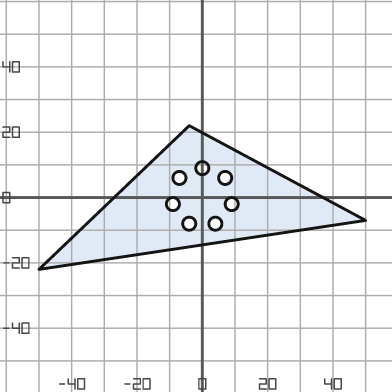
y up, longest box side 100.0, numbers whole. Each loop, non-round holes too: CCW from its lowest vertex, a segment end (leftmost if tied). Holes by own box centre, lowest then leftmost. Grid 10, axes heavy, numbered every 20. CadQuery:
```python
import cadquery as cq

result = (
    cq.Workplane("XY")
    .moveTo(-50.0, -22.0)
    .lineTo(50.0, -7.0)
    .lineTo(-4.0, 22.0)
    .close()
    .moveTo(-4.0, -8.0)
    .circle(2.0)
    .moveTo(4.0, -8.0)
    .circle(2.0)
    .moveTo(-9.0, -2.0)
    .circle(2.0)
    .moveTo(9.0, -2.0)
    .circle(2.0)
    .moveTo(-7.0, 6.0)
    .circle(2.0)
    .moveTo(7.0, 6.0)
    .circle(2.0)
    .moveTo(0.0, 9.0)
    .circle(2.0)
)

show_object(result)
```